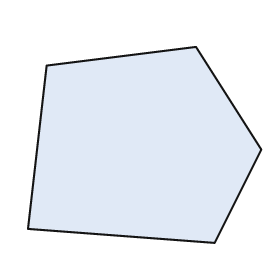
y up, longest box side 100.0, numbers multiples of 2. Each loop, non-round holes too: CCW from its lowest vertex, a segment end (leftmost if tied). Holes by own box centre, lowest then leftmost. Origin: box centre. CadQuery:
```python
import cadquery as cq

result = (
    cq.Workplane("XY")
    .moveTo(30.0, -42.0)
    .lineTo(50.0, -2.0)
    .lineTo(22.0, 42.0)
    .lineTo(-42.0, 34.0)
    .lineTo(-50.0, -36.0)
    .close()
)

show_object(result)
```